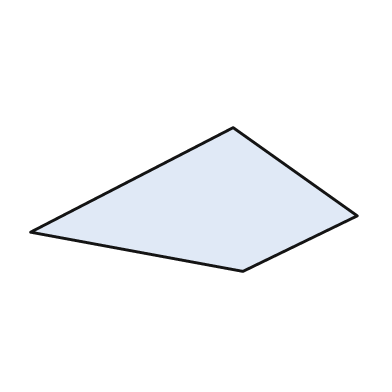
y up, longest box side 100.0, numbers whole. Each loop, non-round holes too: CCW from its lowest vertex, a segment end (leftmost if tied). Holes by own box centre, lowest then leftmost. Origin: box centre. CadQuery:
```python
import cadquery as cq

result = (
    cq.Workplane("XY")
    .moveTo(15.0, -22.0)
    .lineTo(50.0, -5.0)
    .lineTo(12.0, 22.0)
    .lineTo(-50.0, -10.0)
    .close()
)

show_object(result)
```